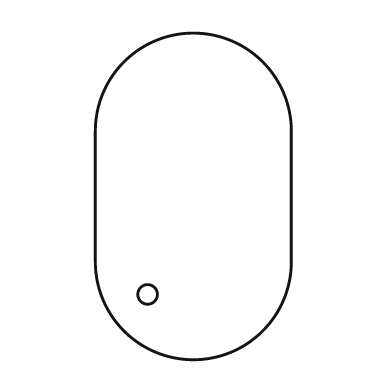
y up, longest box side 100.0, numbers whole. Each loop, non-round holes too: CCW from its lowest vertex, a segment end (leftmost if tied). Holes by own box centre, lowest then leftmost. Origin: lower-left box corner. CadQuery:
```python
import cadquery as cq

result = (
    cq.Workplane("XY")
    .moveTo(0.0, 30.0)
    .threePointArc((30.0, 0.0), (60.0, 30.0))
    .lineTo(60.0, 70.0)
    .threePointArc((30.0, 100.0), (0.0, 70.0))
    .close()
    .moveTo(16.0, 20.0)
    .circle(3.0)
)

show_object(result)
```